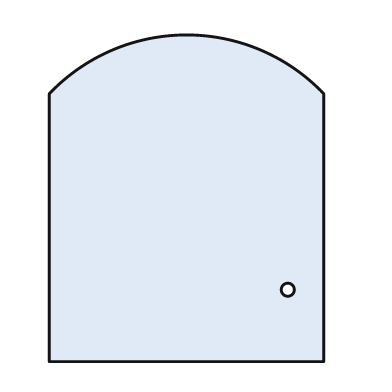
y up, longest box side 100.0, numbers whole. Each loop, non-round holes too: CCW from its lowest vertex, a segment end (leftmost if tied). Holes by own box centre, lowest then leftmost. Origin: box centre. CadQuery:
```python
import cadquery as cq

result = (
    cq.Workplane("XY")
    .moveTo(-42.0, -50.0)
    .lineTo(42.0, -50.0)
    .lineTo(42.0, 32.0)
    .threePointArc((0.0, 50.0), (-42.0, 32.0))
    .close()
    .moveTo(31.0, -28.0)
    .circle(2.0)
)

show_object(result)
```